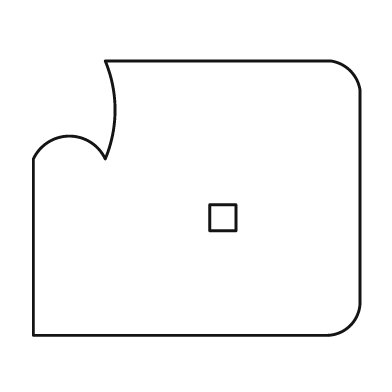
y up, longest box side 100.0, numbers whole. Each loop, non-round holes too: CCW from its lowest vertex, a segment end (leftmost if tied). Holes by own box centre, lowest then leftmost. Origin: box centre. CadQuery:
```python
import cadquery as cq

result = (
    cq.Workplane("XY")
    .moveTo(-50.0, -42.0)
    .lineTo(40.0, -42.0)
    .threePointArc((47.0, -39.0), (50.0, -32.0))
    .lineTo(50.0, 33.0)
    .threePointArc((47.0, 39.0), (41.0, 42.0))
    .lineTo(-28.0, 42.0)
    .threePointArc((-25.0, 27.0), (-28.0, 12.0))
    .threePointArc((-39.0, 19.0), (-50.0, 12.0))
    .close()
    .moveTo(4.0, -10.0)
    .lineTo(12.0, -10.0)
    .lineTo(12.0, -2.0)
    .lineTo(4.0, -2.0)
    .close()
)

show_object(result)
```